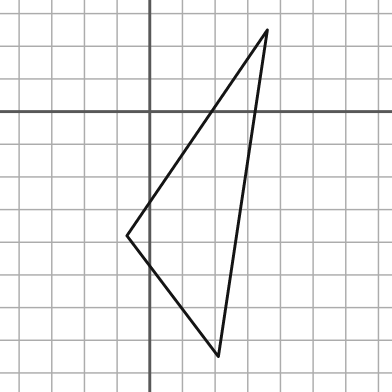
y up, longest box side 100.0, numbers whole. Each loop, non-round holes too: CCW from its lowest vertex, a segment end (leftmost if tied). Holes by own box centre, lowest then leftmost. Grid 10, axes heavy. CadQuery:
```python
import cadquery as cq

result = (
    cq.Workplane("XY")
    .moveTo(21.0, -75.0)
    .lineTo(36.0, 25.0)
    .lineTo(-7.0, -38.0)
    .close()
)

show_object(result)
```